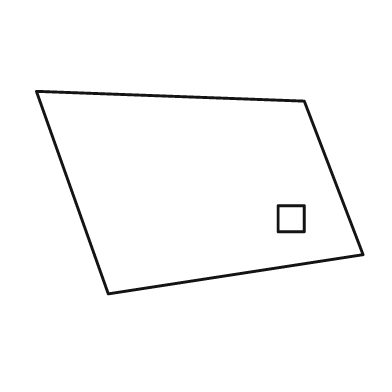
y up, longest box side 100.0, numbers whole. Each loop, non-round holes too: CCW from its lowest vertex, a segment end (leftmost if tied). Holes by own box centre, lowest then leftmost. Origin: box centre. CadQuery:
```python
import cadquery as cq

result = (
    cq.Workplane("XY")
    .moveTo(-28.0, -31.0)
    .lineTo(50.0, -19.0)
    .lineTo(32.0, 28.0)
    .lineTo(-50.0, 31.0)
    .close()
    .moveTo(24.0, -12.0)
    .lineTo(32.0, -12.0)
    .lineTo(32.0, -4.0)
    .lineTo(24.0, -4.0)
    .close()
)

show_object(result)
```